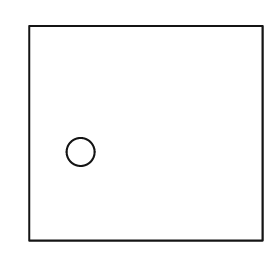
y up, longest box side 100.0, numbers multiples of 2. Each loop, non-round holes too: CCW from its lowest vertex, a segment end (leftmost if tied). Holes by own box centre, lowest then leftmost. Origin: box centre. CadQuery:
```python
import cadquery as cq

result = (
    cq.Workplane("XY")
    .moveTo(-50.0, -46.0)
    .lineTo(50.0, -46.0)
    .lineTo(50.0, 46.0)
    .lineTo(-50.0, 46.0)
    .close()
    .moveTo(-28.0, -8.0)
    .circle(6.0)
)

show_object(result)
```